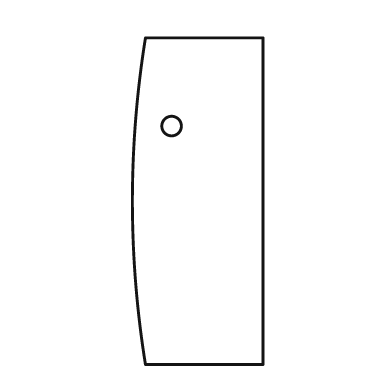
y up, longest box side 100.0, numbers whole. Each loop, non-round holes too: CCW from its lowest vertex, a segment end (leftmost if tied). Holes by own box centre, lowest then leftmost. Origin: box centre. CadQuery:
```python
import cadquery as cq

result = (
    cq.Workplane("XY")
    .moveTo(-16.0, -50.0)
    .lineTo(20.0, -50.0)
    .lineTo(20.0, 50.0)
    .lineTo(-16.0, 50.0)
    .threePointArc((-20.0, 0.0), (-16.0, -50.0))
    .close()
    .moveTo(-8.0, 23.0)
    .circle(3.0)
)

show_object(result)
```